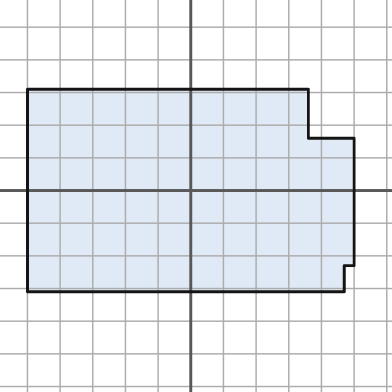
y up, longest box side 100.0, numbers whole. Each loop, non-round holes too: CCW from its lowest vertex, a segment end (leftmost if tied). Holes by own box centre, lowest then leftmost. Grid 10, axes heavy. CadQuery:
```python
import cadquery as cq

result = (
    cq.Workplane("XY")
    .moveTo(-50.0, -31.0)
    .lineTo(47.0, -31.0)
    .lineTo(47.0, -23.0)
    .lineTo(50.0, -23.0)
    .lineTo(50.0, 16.0)
    .lineTo(36.0, 16.0)
    .lineTo(36.0, 31.0)
    .lineTo(-50.0, 31.0)
    .close()
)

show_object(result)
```